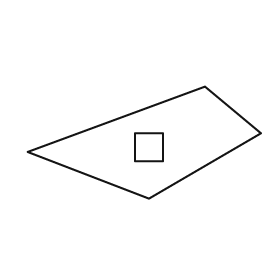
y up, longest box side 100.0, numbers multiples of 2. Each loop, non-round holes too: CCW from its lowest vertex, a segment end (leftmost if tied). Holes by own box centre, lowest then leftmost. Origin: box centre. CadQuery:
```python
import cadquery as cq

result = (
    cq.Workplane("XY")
    .moveTo(2.0, -24.0)
    .lineTo(50.0, 4.0)
    .lineTo(26.0, 24.0)
    .lineTo(-50.0, -4.0)
    .close()
    .moveTo(-4.0, -8.0)
    .lineTo(8.0, -8.0)
    .lineTo(8.0, 4.0)
    .lineTo(-4.0, 4.0)
    .close()
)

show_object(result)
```